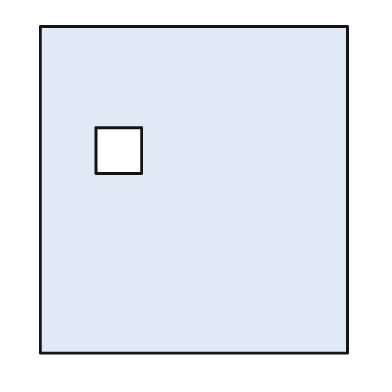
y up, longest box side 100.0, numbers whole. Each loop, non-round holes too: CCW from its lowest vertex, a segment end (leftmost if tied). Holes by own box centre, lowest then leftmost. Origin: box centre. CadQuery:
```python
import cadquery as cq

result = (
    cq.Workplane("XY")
    .moveTo(-47.0, -50.0)
    .lineTo(47.0, -50.0)
    .lineTo(47.0, 50.0)
    .lineTo(-47.0, 50.0)
    .close()
    .moveTo(-30.0, 5.0)
    .lineTo(-16.0, 5.0)
    .lineTo(-16.0, 19.0)
    .lineTo(-30.0, 19.0)
    .close()
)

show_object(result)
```